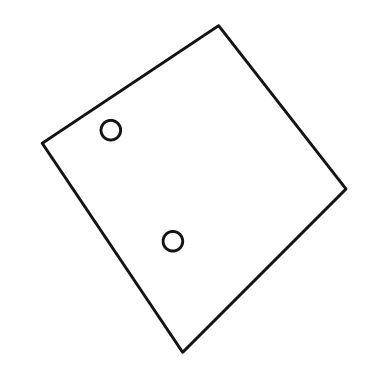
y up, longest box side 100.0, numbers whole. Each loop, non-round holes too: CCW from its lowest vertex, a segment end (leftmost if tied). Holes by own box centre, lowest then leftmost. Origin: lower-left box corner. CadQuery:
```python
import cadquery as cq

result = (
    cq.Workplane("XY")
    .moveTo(43.0, 0.0)
    .lineTo(93.0, 50.0)
    .lineTo(54.0, 100.0)
    .lineTo(0.0, 64.0)
    .close()
    .moveTo(40.0, 34.0)
    .circle(3.0)
    .moveTo(21.0, 68.0)
    .circle(3.0)
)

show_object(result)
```